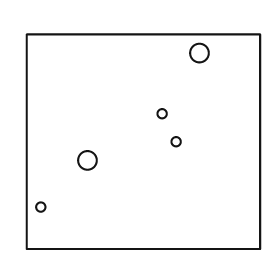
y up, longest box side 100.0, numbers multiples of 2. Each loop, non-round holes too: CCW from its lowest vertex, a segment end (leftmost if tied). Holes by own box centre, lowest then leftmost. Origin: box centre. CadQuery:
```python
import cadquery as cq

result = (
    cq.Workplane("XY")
    .moveTo(-50.0, -46.0)
    .lineTo(50.0, -46.0)
    .lineTo(50.0, 46.0)
    .lineTo(-50.0, 46.0)
    .close()
    .moveTo(-44.0, -28.0)
    .circle(2.0)
    .moveTo(-24.0, -8.0)
    .circle(4.0)
    .moveTo(14.0, 0.0)
    .circle(2.0)
    .moveTo(8.0, 12.0)
    .circle(2.0)
    .moveTo(24.0, 38.0)
    .circle(4.0)
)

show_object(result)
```